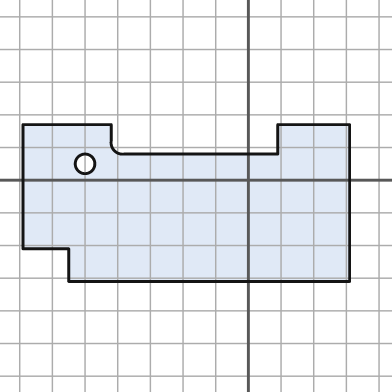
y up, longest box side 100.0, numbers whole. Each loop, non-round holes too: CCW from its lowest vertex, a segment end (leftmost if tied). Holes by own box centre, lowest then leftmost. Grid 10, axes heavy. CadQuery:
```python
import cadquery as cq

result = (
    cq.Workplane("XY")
    .moveTo(-55.0, -31.0)
    .lineTo(31.0, -31.0)
    .lineTo(31.0, 17.0)
    .lineTo(9.0, 17.0)
    .lineTo(9.0, 8.0)
    .lineTo(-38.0, 8.0)
    .threePointArc((-41.0, 9.0), (-42.0, 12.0))
    .lineTo(-42.0, 17.0)
    .lineTo(-69.0, 17.0)
    .lineTo(-69.0, -21.0)
    .lineTo(-55.0, -21.0)
    .close()
    .moveTo(-50.0, 5.0)
    .circle(3.0)
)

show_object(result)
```